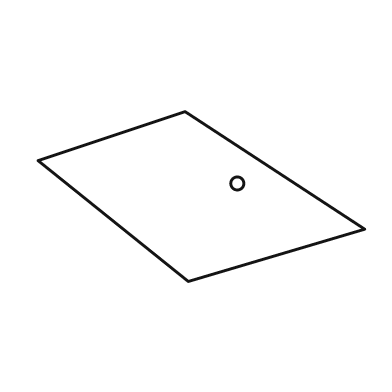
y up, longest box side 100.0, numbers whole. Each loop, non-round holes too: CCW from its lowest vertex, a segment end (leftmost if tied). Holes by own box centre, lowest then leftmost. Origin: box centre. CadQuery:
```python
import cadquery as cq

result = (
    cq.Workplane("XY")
    .moveTo(-4.0, -26.0)
    .lineTo(50.0, -10.0)
    .lineTo(-5.0, 26.0)
    .lineTo(-50.0, 11.0)
    .close()
    .moveTo(11.0, 4.0)
    .circle(2.0)
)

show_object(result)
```